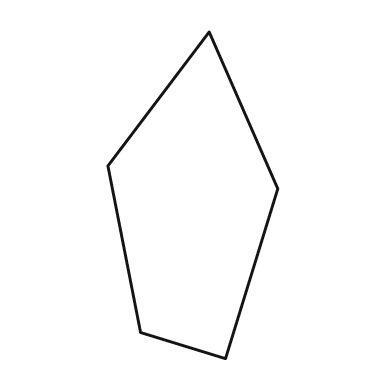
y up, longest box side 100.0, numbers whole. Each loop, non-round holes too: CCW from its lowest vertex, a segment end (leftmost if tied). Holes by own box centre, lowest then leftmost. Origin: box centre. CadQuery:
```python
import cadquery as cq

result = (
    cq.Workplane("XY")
    .moveTo(10.0, -50.0)
    .lineTo(26.0, 2.0)
    .lineTo(5.0, 50.0)
    .lineTo(-26.0, 9.0)
    .lineTo(-16.0, -42.0)
    .close()
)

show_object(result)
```